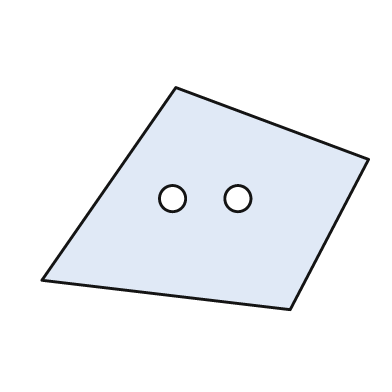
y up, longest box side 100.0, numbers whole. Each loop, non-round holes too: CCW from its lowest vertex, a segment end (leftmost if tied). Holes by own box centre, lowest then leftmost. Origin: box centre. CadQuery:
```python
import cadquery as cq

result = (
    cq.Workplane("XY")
    .moveTo(26.0, -34.0)
    .lineTo(50.0, 12.0)
    .lineTo(-9.0, 34.0)
    .lineTo(-50.0, -25.0)
    .close()
    .moveTo(-10.0, 0.0)
    .circle(4.0)
    .moveTo(10.0, 0.0)
    .circle(4.0)
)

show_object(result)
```